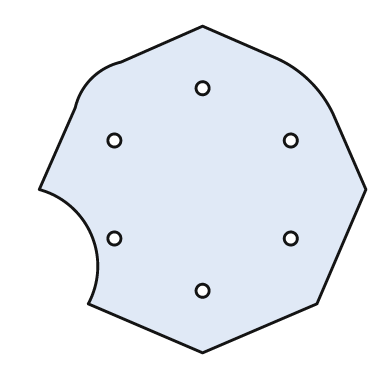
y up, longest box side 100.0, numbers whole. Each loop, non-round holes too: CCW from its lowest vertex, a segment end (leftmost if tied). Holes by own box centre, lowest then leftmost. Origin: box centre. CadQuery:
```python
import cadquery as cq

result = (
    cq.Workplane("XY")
    .moveTo(0.0, -50.0)
    .lineTo(35.0, -35.0)
    .lineTo(50.0, 0.0)
    .lineTo(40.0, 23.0)
    .threePointArc((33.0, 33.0), (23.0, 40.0))
    .lineTo(0.0, 50.0)
    .lineTo(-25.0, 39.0)
    .threePointArc((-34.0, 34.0), (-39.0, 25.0))
    .lineTo(-50.0, 0.0)
    .threePointArc((-34.0, -14.0), (-35.0, -35.0))
    .close()
    .moveTo(0.0, -31.0)
    .circle(2.0)
    .moveTo(-27.0, -15.0)
    .circle(2.0)
    .moveTo(27.0, -15.0)
    .circle(2.0)
    .moveTo(-27.0, 15.0)
    .circle(2.0)
    .moveTo(27.0, 15.0)
    .circle(2.0)
    .moveTo(0.0, 31.0)
    .circle(2.0)
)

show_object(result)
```